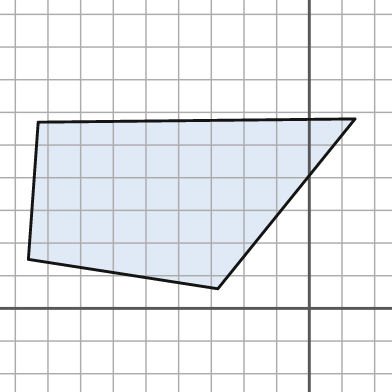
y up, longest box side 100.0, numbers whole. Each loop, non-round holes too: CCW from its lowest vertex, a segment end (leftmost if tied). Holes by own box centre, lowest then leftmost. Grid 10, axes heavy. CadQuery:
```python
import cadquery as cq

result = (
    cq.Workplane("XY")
    .moveTo(-28.0, 6.0)
    .lineTo(14.0, 58.0)
    .lineTo(-83.0, 57.0)
    .lineTo(-86.0, 15.0)
    .close()
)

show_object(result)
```